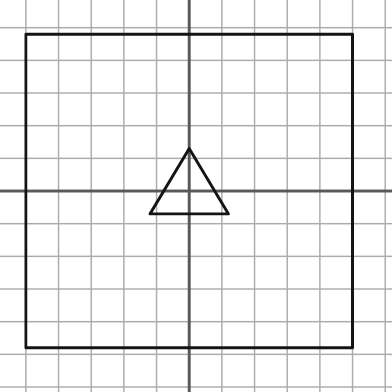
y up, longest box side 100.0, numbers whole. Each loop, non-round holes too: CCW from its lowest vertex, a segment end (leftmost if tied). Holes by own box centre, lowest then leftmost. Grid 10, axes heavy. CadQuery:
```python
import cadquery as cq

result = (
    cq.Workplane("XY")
    .moveTo(-50.0, -48.0)
    .lineTo(50.0, -48.0)
    .lineTo(50.0, 48.0)
    .lineTo(-50.0, 48.0)
    .close()
    .moveTo(-12.0, -7.0)
    .lineTo(12.0, -7.0)
    .lineTo(0.0, 13.0)
    .close()
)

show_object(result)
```